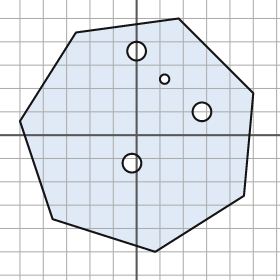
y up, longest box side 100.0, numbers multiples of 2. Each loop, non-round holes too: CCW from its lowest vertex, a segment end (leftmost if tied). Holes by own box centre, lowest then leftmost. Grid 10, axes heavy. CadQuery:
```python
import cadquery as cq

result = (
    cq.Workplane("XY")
    .moveTo(8.0, -50.0)
    .lineTo(46.0, -26.0)
    .lineTo(50.0, 18.0)
    .lineTo(18.0, 50.0)
    .lineTo(-26.0, 44.0)
    .lineTo(-50.0, 6.0)
    .lineTo(-36.0, -36.0)
    .close()
    .moveTo(-2.0, -12.0)
    .circle(4.0)
    .moveTo(28.0, 10.0)
    .circle(4.0)
    .moveTo(12.0, 24.0)
    .circle(2.0)
    .moveTo(0.0, 36.0)
    .circle(4.0)
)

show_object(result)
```